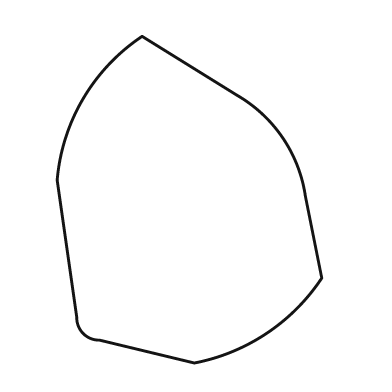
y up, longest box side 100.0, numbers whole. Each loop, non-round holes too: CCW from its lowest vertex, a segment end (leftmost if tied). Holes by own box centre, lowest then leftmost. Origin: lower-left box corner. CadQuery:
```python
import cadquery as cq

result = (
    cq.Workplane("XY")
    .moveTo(42.0, 0.0)
    .threePointArc((64.0, 9.0), (81.0, 26.0))
    .lineTo(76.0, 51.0)
    .threePointArc((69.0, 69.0), (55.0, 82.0))
    .lineTo(26.0, 100.0)
    .threePointArc((8.0, 81.0), (0.0, 56.0))
    .lineTo(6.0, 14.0)
    .threePointArc((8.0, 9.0), (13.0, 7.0))
    .close()
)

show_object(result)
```